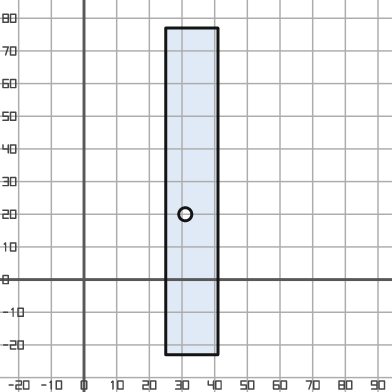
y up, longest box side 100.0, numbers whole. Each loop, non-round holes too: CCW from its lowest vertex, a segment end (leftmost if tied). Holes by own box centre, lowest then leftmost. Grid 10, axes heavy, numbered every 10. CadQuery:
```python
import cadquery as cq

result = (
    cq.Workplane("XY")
    .moveTo(25.0, -23.0)
    .lineTo(41.0, -23.0)
    .lineTo(41.0, 77.0)
    .lineTo(25.0, 77.0)
    .close()
    .moveTo(31.0, 20.0)
    .circle(2.0)
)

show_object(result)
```